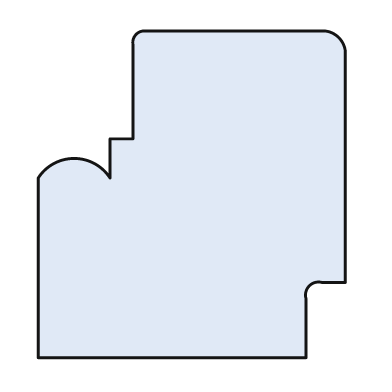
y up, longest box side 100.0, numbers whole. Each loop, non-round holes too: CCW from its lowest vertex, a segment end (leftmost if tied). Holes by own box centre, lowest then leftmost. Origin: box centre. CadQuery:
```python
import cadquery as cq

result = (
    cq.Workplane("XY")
    .moveTo(-47.0, -50.0)
    .lineTo(35.0, -50.0)
    .lineTo(35.0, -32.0)
    .threePointArc((36.0, -28.0), (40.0, -27.0))
    .lineTo(47.0, -27.0)
    .lineTo(47.0, 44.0)
    .threePointArc((45.0, 48.0), (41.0, 50.0))
    .lineTo(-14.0, 50.0)
    .threePointArc((-17.0, 49.0), (-18.0, 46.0))
    .lineTo(-18.0, 17.0)
    .lineTo(-25.0, 17.0)
    .lineTo(-25.0, 5.0)
    .threePointArc((-36.0, 11.0), (-47.0, 5.0))
    .close()
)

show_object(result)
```